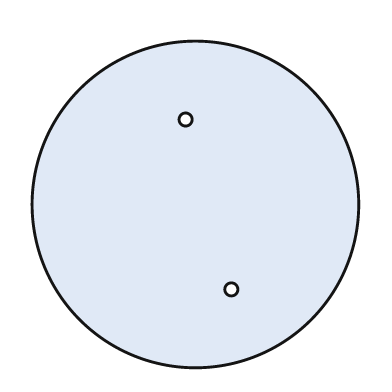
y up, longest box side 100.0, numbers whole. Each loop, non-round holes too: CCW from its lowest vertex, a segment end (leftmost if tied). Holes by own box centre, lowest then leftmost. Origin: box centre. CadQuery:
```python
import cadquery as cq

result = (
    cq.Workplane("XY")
    .moveTo(0.0, 0.0)
    .circle(50.0)
    .moveTo(11.0, -26.0)
    .circle(2.0)
    .moveTo(-3.0, 26.0)
    .circle(2.0)
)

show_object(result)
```